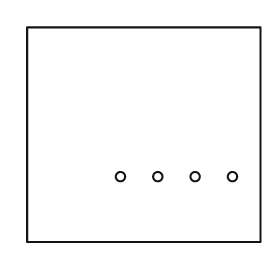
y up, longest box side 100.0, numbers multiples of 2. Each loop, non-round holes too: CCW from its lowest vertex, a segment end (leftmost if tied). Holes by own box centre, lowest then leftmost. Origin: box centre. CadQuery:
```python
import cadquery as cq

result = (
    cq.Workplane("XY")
    .moveTo(-50.0, -46.0)
    .lineTo(50.0, -46.0)
    .lineTo(50.0, 46.0)
    .lineTo(-50.0, 46.0)
    .close()
    .moveTo(-10.0, -18.0)
    .circle(2.0)
    .moveTo(6.0, -18.0)
    .circle(2.0)
    .moveTo(22.0, -18.0)
    .circle(2.0)
    .moveTo(38.0, -18.0)
    .circle(2.0)
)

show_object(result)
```